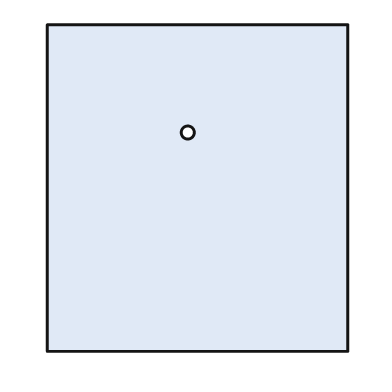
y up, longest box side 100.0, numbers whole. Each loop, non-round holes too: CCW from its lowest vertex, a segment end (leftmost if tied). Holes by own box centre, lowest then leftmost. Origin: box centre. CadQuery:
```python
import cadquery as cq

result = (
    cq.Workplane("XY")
    .moveTo(-46.0, -50.0)
    .lineTo(46.0, -50.0)
    .lineTo(46.0, 50.0)
    .lineTo(-46.0, 50.0)
    .close()
    .moveTo(-3.0, 17.0)
    .circle(2.0)
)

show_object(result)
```